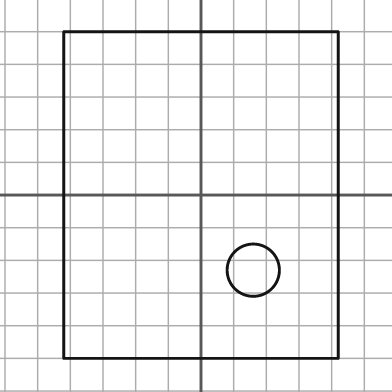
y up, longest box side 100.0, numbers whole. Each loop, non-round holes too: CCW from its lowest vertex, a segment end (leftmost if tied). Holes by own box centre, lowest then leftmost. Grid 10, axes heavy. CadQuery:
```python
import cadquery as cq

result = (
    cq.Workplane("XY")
    .moveTo(-42.0, -50.0)
    .lineTo(42.0, -50.0)
    .lineTo(42.0, 50.0)
    .lineTo(-42.0, 50.0)
    .close()
    .moveTo(16.0, -23.0)
    .circle(8.0)
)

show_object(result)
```